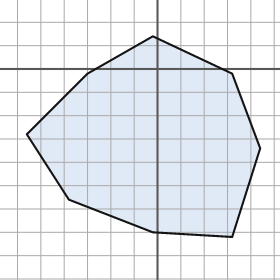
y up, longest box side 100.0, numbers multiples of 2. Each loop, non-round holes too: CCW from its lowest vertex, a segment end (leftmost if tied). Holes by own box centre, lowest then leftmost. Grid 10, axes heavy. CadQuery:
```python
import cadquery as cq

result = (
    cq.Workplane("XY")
    .moveTo(32.0, -72.0)
    .lineTo(44.0, -34.0)
    .lineTo(32.0, -2.0)
    .lineTo(-2.0, 14.0)
    .lineTo(-30.0, -2.0)
    .lineTo(-56.0, -28.0)
    .lineTo(-38.0, -56.0)
    .lineTo(-2.0, -70.0)
    .close()
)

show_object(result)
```